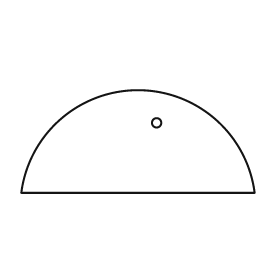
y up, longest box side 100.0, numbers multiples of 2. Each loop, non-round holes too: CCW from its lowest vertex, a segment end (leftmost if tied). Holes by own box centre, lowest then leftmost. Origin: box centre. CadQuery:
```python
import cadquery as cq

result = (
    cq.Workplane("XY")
    .moveTo(-50.0, -22.0)
    .lineTo(50.0, -22.0)
    .threePointArc((0.0, 22.0), (-50.0, -22.0))
    .close()
    .moveTo(8.0, 8.0)
    .circle(2.0)
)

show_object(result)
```